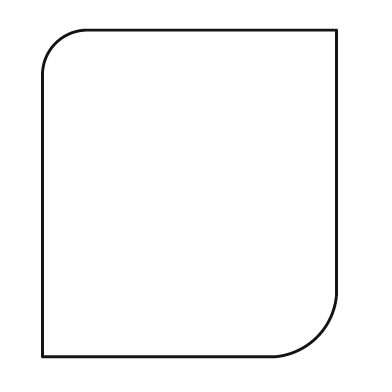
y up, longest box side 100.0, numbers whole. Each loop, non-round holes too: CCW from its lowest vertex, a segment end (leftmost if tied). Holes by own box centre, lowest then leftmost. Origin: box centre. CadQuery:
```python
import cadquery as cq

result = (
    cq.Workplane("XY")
    .moveTo(-45.0, -50.0)
    .lineTo(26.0, -50.0)
    .threePointArc((39.0, -44.0), (45.0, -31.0))
    .lineTo(45.0, 50.0)
    .lineTo(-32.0, 50.0)
    .threePointArc((-41.0, 46.0), (-45.0, 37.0))
    .close()
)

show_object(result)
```